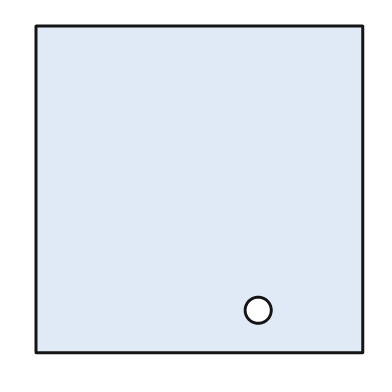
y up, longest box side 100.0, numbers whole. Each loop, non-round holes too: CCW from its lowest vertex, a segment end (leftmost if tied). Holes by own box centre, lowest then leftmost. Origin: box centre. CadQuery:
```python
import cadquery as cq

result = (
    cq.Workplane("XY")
    .moveTo(-50.0, -50.0)
    .lineTo(50.0, -50.0)
    .lineTo(50.0, 50.0)
    .lineTo(-50.0, 50.0)
    .close()
    .moveTo(18.0, -37.0)
    .circle(4.0)
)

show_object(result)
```